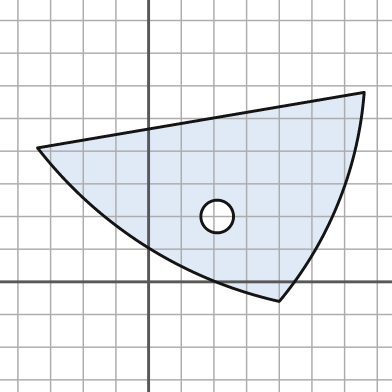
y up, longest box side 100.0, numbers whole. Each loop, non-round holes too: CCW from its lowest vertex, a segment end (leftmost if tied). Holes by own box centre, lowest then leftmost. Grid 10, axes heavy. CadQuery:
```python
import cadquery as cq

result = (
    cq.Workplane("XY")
    .moveTo(40.0, -6.0)
    .threePointArc((58.0, 24.0), (66.0, 58.0))
    .lineTo(-34.0, 41.0)
    .threePointArc((-1.0, 11.0), (40.0, -6.0))
    .close()
    .moveTo(21.0, 20.0)
    .circle(5.0)
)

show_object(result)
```